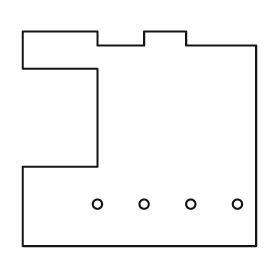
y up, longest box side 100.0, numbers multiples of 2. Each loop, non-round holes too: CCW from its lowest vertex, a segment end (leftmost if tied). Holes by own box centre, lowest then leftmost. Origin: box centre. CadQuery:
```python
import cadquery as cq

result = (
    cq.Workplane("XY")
    .moveTo(-50.0, -46.0)
    .lineTo(50.0, -46.0)
    .lineTo(50.0, 40.0)
    .lineTo(20.0, 40.0)
    .lineTo(20.0, 46.0)
    .lineTo(2.0, 46.0)
    .lineTo(2.0, 40.0)
    .lineTo(-18.0, 40.0)
    .lineTo(-18.0, 46.0)
    .lineTo(-50.0, 46.0)
    .lineTo(-50.0, 30.0)
    .lineTo(-18.0, 30.0)
    .lineTo(-18.0, -12.0)
    .lineTo(-50.0, -12.0)
    .close()
    .moveTo(-18.0, -28.0)
    .circle(2.0)
    .moveTo(2.0, -28.0)
    .circle(2.0)
    .moveTo(22.0, -28.0)
    .circle(2.0)
    .moveTo(42.0, -28.0)
    .circle(2.0)
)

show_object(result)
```